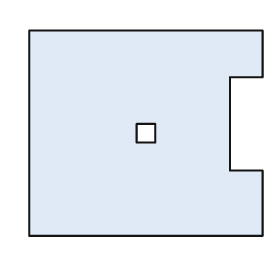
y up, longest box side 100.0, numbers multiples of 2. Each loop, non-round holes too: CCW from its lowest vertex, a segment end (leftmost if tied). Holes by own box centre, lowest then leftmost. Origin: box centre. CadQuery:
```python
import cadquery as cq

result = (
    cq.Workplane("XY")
    .moveTo(-50.0, -44.0)
    .lineTo(50.0, -44.0)
    .lineTo(50.0, -16.0)
    .lineTo(36.0, -16.0)
    .lineTo(36.0, 24.0)
    .lineTo(50.0, 24.0)
    .lineTo(50.0, 44.0)
    .lineTo(-50.0, 44.0)
    .close()
    .moveTo(-4.0, -4.0)
    .lineTo(4.0, -4.0)
    .lineTo(4.0, 4.0)
    .lineTo(-4.0, 4.0)
    .close()
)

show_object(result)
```